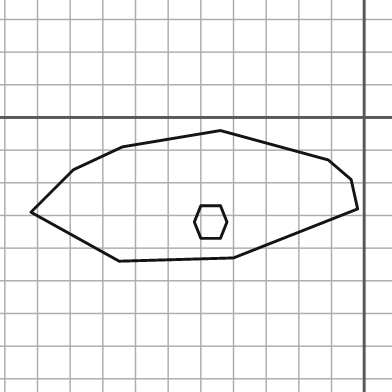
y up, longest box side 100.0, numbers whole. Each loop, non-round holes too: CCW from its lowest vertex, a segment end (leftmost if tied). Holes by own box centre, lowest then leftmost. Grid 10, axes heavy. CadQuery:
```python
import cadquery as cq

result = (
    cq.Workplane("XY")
    .moveTo(-75.0, -44.0)
    .lineTo(-40.0, -43.0)
    .lineTo(-2.0, -28.0)
    .lineTo(-4.0, -19.0)
    .lineTo(-11.0, -13.0)
    .lineTo(-44.0, -4.0)
    .lineTo(-74.0, -9.0)
    .lineTo(-89.0, -16.0)
    .lineTo(-102.0, -29.0)
    .close()
    .moveTo(-50.0, -37.0)
    .lineTo(-44.0, -37.0)
    .lineTo(-42.0, -32.0)
    .lineTo(-44.0, -27.0)
    .lineTo(-50.0, -27.0)
    .lineTo(-52.0, -32.0)
    .close()
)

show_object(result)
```